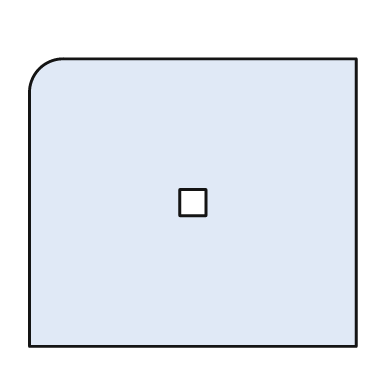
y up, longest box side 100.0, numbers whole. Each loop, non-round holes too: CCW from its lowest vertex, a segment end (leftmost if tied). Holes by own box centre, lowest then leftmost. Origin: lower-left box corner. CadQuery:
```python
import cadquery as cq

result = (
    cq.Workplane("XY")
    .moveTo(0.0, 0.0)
    .lineTo(100.0, 0.0)
    .lineTo(100.0, 88.0)
    .lineTo(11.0, 88.0)
    .threePointArc((3.0, 85.0), (0.0, 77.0))
    .close()
    .moveTo(46.0, 40.0)
    .lineTo(54.0, 40.0)
    .lineTo(54.0, 48.0)
    .lineTo(46.0, 48.0)
    .close()
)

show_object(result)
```